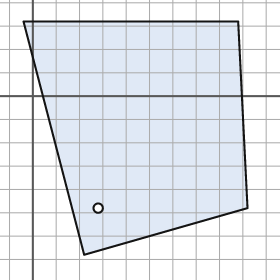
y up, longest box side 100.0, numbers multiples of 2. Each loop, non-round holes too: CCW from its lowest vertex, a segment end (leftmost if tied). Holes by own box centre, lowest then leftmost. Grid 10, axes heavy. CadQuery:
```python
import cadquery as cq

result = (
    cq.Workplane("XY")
    .moveTo(22.0, -68.0)
    .lineTo(92.0, -48.0)
    .lineTo(88.0, 32.0)
    .lineTo(-4.0, 32.0)
    .close()
    .moveTo(28.0, -48.0)
    .circle(2.0)
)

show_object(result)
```